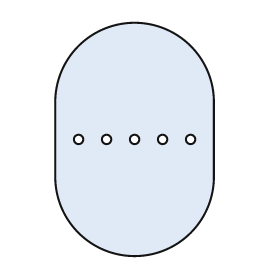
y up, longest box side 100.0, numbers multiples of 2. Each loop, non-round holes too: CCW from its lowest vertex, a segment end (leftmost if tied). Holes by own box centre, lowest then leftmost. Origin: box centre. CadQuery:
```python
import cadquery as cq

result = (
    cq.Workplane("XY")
    .moveTo(-34.0, -16.0)
    .threePointArc((0.0, -50.0), (34.0, -16.0))
    .lineTo(34.0, 16.0)
    .threePointArc((0.0, 50.0), (-34.0, 16.0))
    .close()
    .moveTo(-24.0, 0.0)
    .circle(2.0)
    .moveTo(-12.0, 0.0)
    .circle(2.0)
    .moveTo(0.0, 0.0)
    .circle(2.0)
    .moveTo(12.0, 0.0)
    .circle(2.0)
    .moveTo(24.0, 0.0)
    .circle(2.0)
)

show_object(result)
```